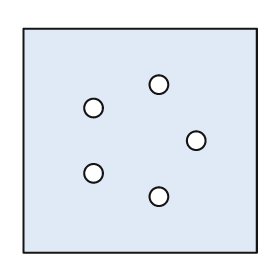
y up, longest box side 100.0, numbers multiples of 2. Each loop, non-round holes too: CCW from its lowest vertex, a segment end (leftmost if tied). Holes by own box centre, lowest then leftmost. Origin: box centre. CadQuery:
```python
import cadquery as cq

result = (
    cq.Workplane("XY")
    .moveTo(-50.0, -48.0)
    .lineTo(50.0, -48.0)
    .lineTo(50.0, 48.0)
    .lineTo(-50.0, 48.0)
    .close()
    .moveTo(8.0, -24.0)
    .circle(4.0)
    .moveTo(-20.0, -14.0)
    .circle(4.0)
    .moveTo(24.0, 0.0)
    .circle(4.0)
    .moveTo(-20.0, 14.0)
    .circle(4.0)
    .moveTo(8.0, 24.0)
    .circle(4.0)
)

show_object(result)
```